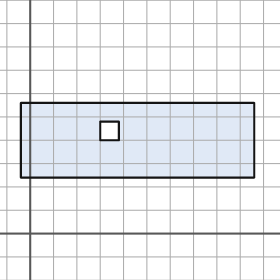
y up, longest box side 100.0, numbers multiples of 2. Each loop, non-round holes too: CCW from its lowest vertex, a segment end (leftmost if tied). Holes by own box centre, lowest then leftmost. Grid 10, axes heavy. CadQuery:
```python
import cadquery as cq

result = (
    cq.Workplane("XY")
    .moveTo(-4.0, 24.0)
    .lineTo(96.0, 24.0)
    .lineTo(96.0, 56.0)
    .lineTo(-4.0, 56.0)
    .close()
    .moveTo(30.0, 40.0)
    .lineTo(38.0, 40.0)
    .lineTo(38.0, 48.0)
    .lineTo(30.0, 48.0)
    .close()
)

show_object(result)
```